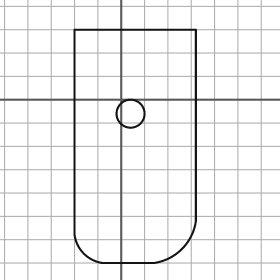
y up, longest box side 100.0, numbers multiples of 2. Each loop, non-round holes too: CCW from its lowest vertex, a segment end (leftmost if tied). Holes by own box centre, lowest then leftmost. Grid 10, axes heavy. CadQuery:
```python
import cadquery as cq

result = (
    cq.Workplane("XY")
    .moveTo(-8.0, -70.0)
    .lineTo(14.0, -70.0)
    .threePointArc((26.0, -64.0), (32.0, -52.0))
    .lineTo(32.0, 30.0)
    .lineTo(-20.0, 30.0)
    .lineTo(-20.0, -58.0)
    .threePointArc((-16.0, -66.0), (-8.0, -70.0))
    .close()
    .moveTo(4.0, -6.0)
    .circle(6.0)
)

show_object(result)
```